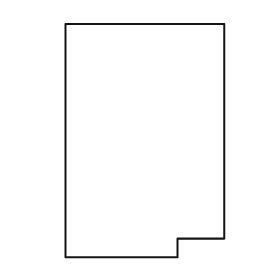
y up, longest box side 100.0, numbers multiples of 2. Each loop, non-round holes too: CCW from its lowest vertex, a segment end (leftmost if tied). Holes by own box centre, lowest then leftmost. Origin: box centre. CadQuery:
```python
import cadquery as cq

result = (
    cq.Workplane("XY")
    .moveTo(-34.0, -50.0)
    .lineTo(14.0, -50.0)
    .lineTo(14.0, -42.0)
    .lineTo(34.0, -42.0)
    .lineTo(34.0, 50.0)
    .lineTo(-34.0, 50.0)
    .close()
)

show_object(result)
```